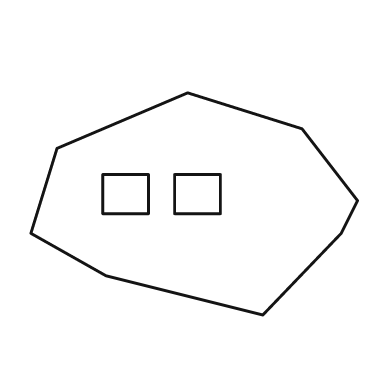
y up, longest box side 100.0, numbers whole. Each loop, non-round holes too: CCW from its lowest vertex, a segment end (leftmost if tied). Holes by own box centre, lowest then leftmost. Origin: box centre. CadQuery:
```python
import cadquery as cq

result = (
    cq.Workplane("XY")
    .moveTo(21.0, -34.0)
    .lineTo(45.0, -9.0)
    .lineTo(50.0, 1.0)
    .lineTo(33.0, 23.0)
    .lineTo(-2.0, 34.0)
    .lineTo(-42.0, 17.0)
    .lineTo(-50.0, -9.0)
    .lineTo(-27.0, -22.0)
    .close()
    .moveTo(-28.0, -3.0)
    .lineTo(-14.0, -3.0)
    .lineTo(-14.0, 9.0)
    .lineTo(-28.0, 9.0)
    .close()
    .moveTo(-6.0, -3.0)
    .lineTo(8.0, -3.0)
    .lineTo(8.0, 9.0)
    .lineTo(-6.0, 9.0)
    .close()
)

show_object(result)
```